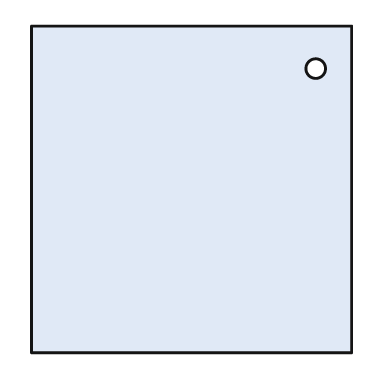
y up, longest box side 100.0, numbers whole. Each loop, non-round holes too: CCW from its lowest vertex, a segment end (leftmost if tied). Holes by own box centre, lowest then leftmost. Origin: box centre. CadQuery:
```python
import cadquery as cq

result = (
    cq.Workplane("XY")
    .moveTo(-49.0, -50.0)
    .lineTo(49.0, -50.0)
    .lineTo(49.0, 50.0)
    .lineTo(-49.0, 50.0)
    .close()
    .moveTo(38.0, 37.0)
    .circle(3.0)
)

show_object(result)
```